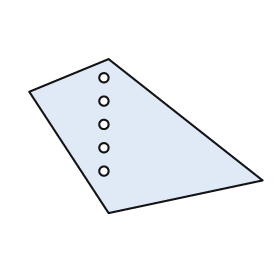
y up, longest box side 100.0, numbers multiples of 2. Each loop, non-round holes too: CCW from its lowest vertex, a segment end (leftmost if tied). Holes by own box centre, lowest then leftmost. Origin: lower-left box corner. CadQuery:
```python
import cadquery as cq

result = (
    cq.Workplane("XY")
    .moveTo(34.0, 0.0)
    .lineTo(100.0, 14.0)
    .lineTo(34.0, 66.0)
    .lineTo(0.0, 52.0)
    .close()
    .moveTo(32.0, 18.0)
    .circle(2.0)
    .moveTo(32.0, 28.0)
    .circle(2.0)
    .moveTo(32.0, 38.0)
    .circle(2.0)
    .moveTo(32.0, 48.0)
    .circle(2.0)
    .moveTo(32.0, 58.0)
    .circle(2.0)
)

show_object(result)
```